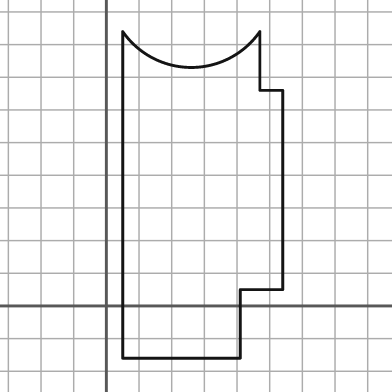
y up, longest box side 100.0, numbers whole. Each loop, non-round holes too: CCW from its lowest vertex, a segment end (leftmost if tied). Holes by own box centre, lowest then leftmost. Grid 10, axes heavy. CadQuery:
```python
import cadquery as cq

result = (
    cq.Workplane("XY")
    .moveTo(5.0, -16.0)
    .lineTo(41.0, -16.0)
    .lineTo(41.0, 5.0)
    .lineTo(54.0, 5.0)
    .lineTo(54.0, 66.0)
    .lineTo(47.0, 66.0)
    .lineTo(47.0, 84.0)
    .threePointArc((26.0, 73.0), (5.0, 84.0))
    .close()
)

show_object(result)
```